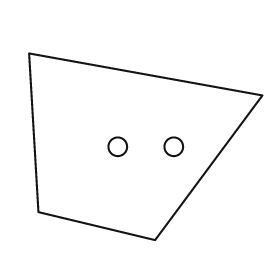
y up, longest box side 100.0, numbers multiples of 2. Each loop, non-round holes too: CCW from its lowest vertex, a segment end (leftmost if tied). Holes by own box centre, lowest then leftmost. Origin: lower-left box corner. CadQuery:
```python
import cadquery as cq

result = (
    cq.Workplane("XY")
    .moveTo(54.0, 0.0)
    .lineTo(100.0, 62.0)
    .lineTo(0.0, 80.0)
    .lineTo(4.0, 12.0)
    .close()
    .moveTo(38.0, 40.0)
    .circle(4.0)
    .moveTo(62.0, 40.0)
    .circle(4.0)
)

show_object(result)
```